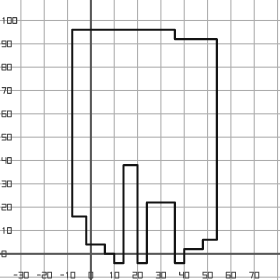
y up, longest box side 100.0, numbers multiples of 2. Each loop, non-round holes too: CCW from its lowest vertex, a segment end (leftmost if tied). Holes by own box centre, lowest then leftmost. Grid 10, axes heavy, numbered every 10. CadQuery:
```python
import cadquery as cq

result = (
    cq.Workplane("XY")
    .moveTo(10.0, -4.0)
    .lineTo(14.0, -4.0)
    .lineTo(14.0, 38.0)
    .lineTo(20.0, 38.0)
    .lineTo(20.0, -4.0)
    .lineTo(24.0, -4.0)
    .lineTo(24.0, 22.0)
    .lineTo(36.0, 22.0)
    .lineTo(36.0, -4.0)
    .lineTo(40.0, -4.0)
    .lineTo(40.0, 2.0)
    .lineTo(48.0, 2.0)
    .lineTo(48.0, 6.0)
    .lineTo(54.0, 6.0)
    .lineTo(54.0, 92.0)
    .lineTo(36.0, 92.0)
    .lineTo(36.0, 96.0)
    .lineTo(-8.0, 96.0)
    .lineTo(-8.0, 16.0)
    .lineTo(-2.0, 16.0)
    .lineTo(-2.0, 4.0)
    .lineTo(6.0, 4.0)
    .lineTo(6.0, 0.0)
    .lineTo(10.0, 0.0)
    .close()
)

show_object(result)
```